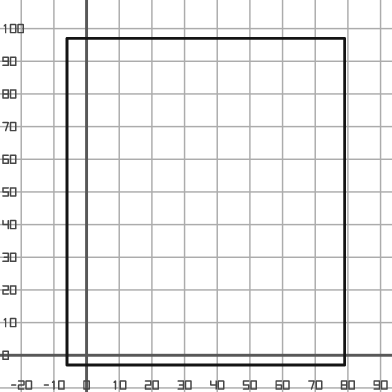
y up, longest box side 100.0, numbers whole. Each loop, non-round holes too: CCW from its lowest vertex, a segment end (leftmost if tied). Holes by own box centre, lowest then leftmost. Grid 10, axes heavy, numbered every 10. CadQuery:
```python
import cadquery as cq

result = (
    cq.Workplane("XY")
    .moveTo(-6.0, -3.0)
    .lineTo(79.0, -3.0)
    .lineTo(79.0, 97.0)
    .lineTo(-6.0, 97.0)
    .close()
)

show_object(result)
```